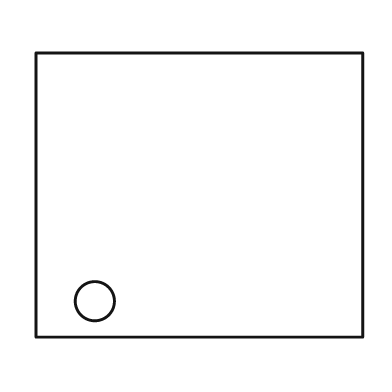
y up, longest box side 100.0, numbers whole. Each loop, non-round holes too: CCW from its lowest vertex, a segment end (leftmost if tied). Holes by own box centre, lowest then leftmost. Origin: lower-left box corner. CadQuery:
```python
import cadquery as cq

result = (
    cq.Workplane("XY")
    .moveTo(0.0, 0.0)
    .lineTo(100.0, 0.0)
    .lineTo(100.0, 87.0)
    .lineTo(0.0, 87.0)
    .close()
    .moveTo(18.0, 11.0)
    .circle(6.0)
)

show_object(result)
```